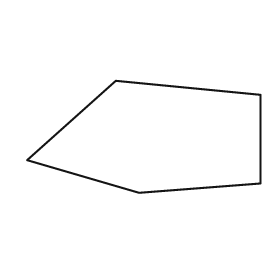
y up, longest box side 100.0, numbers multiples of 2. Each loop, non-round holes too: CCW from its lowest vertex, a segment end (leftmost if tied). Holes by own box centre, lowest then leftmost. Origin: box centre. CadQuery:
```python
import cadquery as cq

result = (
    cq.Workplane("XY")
    .moveTo(-2.0, -24.0)
    .lineTo(50.0, -20.0)
    .lineTo(50.0, 18.0)
    .lineTo(-12.0, 24.0)
    .lineTo(-50.0, -10.0)
    .close()
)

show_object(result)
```